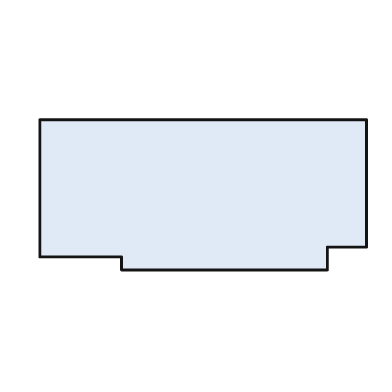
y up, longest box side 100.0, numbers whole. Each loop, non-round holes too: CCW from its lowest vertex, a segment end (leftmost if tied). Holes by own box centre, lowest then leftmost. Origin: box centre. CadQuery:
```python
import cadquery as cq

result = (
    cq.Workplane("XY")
    .moveTo(-25.0, -23.0)
    .lineTo(38.0, -23.0)
    .lineTo(38.0, -16.0)
    .lineTo(50.0, -16.0)
    .lineTo(50.0, 23.0)
    .lineTo(-50.0, 23.0)
    .lineTo(-50.0, -19.0)
    .lineTo(-25.0, -19.0)
    .close()
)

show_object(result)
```